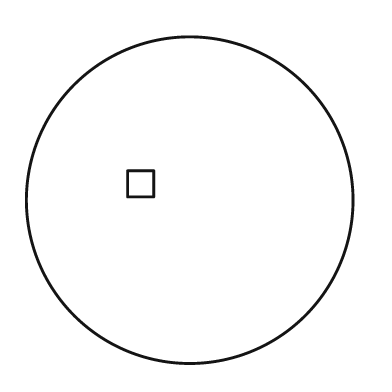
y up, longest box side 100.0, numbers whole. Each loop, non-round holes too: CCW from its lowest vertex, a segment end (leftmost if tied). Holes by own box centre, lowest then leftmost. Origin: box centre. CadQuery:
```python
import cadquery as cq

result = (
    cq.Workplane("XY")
    .moveTo(0.0, 0.0)
    .circle(50.0)
    .moveTo(-19.0, 1.0)
    .lineTo(-11.0, 1.0)
    .lineTo(-11.0, 9.0)
    .lineTo(-19.0, 9.0)
    .close()
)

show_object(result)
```